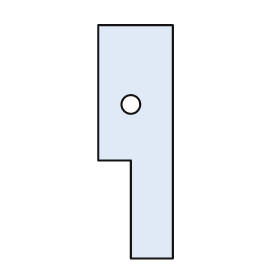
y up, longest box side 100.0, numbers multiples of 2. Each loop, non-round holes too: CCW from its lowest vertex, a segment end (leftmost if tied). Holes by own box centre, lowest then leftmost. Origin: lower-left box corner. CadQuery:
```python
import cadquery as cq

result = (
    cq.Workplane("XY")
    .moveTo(14.0, 0.0)
    .lineTo(32.0, 0.0)
    .lineTo(32.0, 100.0)
    .lineTo(0.0, 100.0)
    .lineTo(0.0, 42.0)
    .lineTo(14.0, 42.0)
    .close()
    .moveTo(14.0, 66.0)
    .circle(4.0)
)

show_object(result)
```